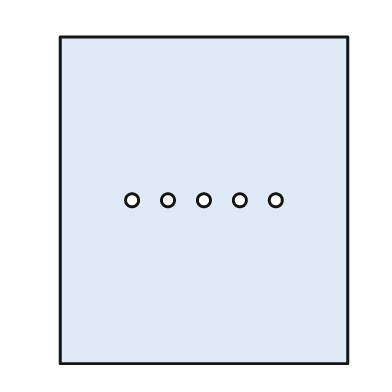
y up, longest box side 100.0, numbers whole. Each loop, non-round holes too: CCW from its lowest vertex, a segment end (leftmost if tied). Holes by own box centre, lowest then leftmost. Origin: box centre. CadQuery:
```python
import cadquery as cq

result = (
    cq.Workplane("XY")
    .moveTo(-44.0, -50.0)
    .lineTo(44.0, -50.0)
    .lineTo(44.0, 50.0)
    .lineTo(-44.0, 50.0)
    .close()
    .moveTo(-22.0, 0.0)
    .circle(2.0)
    .moveTo(-11.0, 0.0)
    .circle(2.0)
    .moveTo(0.0, 0.0)
    .circle(2.0)
    .moveTo(11.0, 0.0)
    .circle(2.0)
    .moveTo(22.0, 0.0)
    .circle(2.0)
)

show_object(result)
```